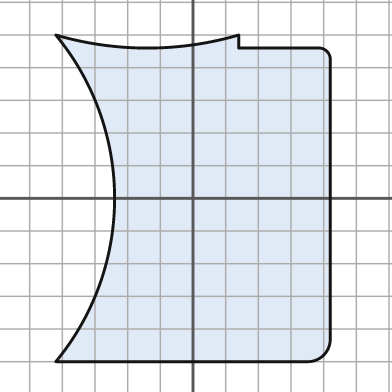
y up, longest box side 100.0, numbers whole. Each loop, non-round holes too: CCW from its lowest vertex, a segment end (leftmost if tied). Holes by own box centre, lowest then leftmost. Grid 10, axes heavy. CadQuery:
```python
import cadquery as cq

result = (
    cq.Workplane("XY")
    .moveTo(-42.0, -50.0)
    .lineTo(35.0, -50.0)
    .threePointArc((40.0, -48.0), (42.0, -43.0))
    .lineTo(42.0, 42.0)
    .threePointArc((41.0, 45.0), (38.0, 46.0))
    .lineTo(14.0, 46.0)
    .lineTo(14.0, 50.0)
    .threePointArc((-14.0, 46.0), (-42.0, 50.0))
    .threePointArc((-24.0, 0.0), (-42.0, -50.0))
    .close()
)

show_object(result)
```